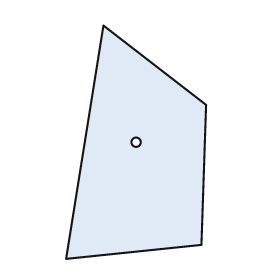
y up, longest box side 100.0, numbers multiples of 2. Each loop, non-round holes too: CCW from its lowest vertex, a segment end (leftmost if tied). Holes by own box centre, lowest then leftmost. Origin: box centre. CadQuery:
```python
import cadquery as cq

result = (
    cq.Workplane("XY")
    .moveTo(-30.0, -50.0)
    .lineTo(28.0, -44.0)
    .lineTo(30.0, 16.0)
    .lineTo(-14.0, 50.0)
    .close()
    .moveTo(0.0, 0.0)
    .circle(2.0)
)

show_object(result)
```